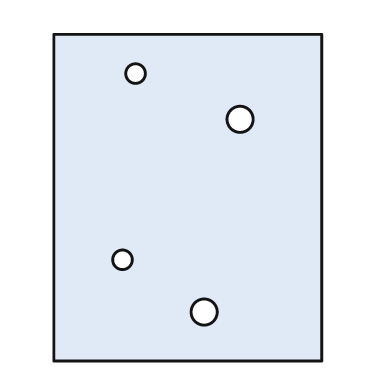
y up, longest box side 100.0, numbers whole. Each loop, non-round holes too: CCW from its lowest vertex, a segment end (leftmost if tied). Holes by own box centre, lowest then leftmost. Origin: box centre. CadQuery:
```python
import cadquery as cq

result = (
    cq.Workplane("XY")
    .moveTo(-41.0, -50.0)
    .lineTo(41.0, -50.0)
    .lineTo(41.0, 50.0)
    .lineTo(-41.0, 50.0)
    .close()
    .moveTo(5.0, -35.0)
    .circle(4.0)
    .moveTo(-20.0, -19.0)
    .circle(3.0)
    .moveTo(16.0, 24.0)
    .circle(4.0)
    .moveTo(-16.0, 38.0)
    .circle(3.0)
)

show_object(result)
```